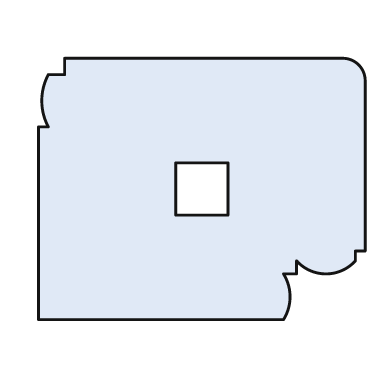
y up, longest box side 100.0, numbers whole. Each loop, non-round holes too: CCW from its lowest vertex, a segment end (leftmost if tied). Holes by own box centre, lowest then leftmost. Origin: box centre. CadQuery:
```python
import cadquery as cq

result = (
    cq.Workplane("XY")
    .moveTo(-50.0, -40.0)
    .lineTo(25.0, -40.0)
    .threePointArc((27.0, -33.0), (25.0, -26.0))
    .lineTo(29.0, -26.0)
    .lineTo(29.0, -22.0)
    .threePointArc((38.0, -26.0), (47.0, -22.0))
    .lineTo(47.0, -19.0)
    .lineTo(50.0, -19.0)
    .lineTo(50.0, 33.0)
    .threePointArc((48.0, 38.0), (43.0, 40.0))
    .lineTo(-42.0, 40.0)
    .lineTo(-42.0, 35.0)
    .lineTo(-47.0, 35.0)
    .threePointArc((-49.0, 27.0), (-47.0, 19.0))
    .lineTo(-50.0, 19.0)
    .close()
    .moveTo(-8.0, -8.0)
    .lineTo(8.0, -8.0)
    .lineTo(8.0, 8.0)
    .lineTo(-8.0, 8.0)
    .close()
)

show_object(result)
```